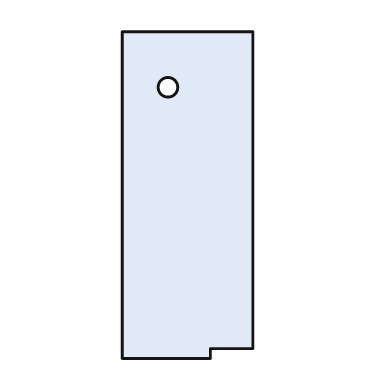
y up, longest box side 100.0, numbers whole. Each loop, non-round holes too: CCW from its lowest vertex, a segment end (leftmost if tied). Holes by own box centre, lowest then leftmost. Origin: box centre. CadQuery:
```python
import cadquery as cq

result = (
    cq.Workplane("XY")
    .moveTo(-20.0, -50.0)
    .lineTo(7.0, -50.0)
    .lineTo(7.0, -47.0)
    .lineTo(20.0, -47.0)
    .lineTo(20.0, 50.0)
    .lineTo(-20.0, 50.0)
    .close()
    .moveTo(-6.0, 33.0)
    .circle(3.0)
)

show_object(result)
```